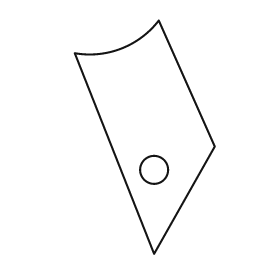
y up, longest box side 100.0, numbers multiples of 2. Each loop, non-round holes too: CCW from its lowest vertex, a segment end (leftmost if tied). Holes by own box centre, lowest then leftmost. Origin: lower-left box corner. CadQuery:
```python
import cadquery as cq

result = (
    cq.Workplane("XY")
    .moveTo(34.0, 0.0)
    .lineTo(60.0, 46.0)
    .lineTo(36.0, 100.0)
    .threePointArc((20.0, 88.0), (0.0, 86.0))
    .close()
    .moveTo(34.0, 36.0)
    .circle(6.0)
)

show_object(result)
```